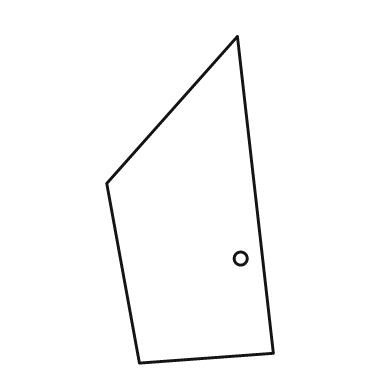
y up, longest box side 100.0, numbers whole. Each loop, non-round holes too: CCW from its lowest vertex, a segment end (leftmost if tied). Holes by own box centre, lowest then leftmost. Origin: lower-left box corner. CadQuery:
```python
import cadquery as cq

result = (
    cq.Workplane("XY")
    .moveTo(10.0, 0.0)
    .lineTo(51.0, 3.0)
    .lineTo(40.0, 100.0)
    .lineTo(0.0, 55.0)
    .close()
    .moveTo(41.0, 32.0)
    .circle(2.0)
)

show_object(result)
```